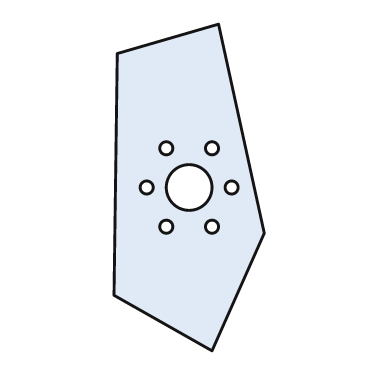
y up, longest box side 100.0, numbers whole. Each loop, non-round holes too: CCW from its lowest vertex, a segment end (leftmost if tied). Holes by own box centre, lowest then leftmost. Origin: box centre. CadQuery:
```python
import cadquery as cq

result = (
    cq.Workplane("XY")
    .moveTo(7.0, -50.0)
    .lineTo(23.0, -14.0)
    .lineTo(9.0, 50.0)
    .lineTo(-22.0, 41.0)
    .lineTo(-23.0, -33.0)
    .close()
    .moveTo(-7.0, -12.0)
    .circle(2.0)
    .moveTo(7.0, -12.0)
    .circle(2.0)
    .moveTo(-13.0, 0.0)
    .circle(2.0)
    .moveTo(0.0, 0.0)
    .circle(7.0)
    .moveTo(13.0, 0.0)
    .circle(2.0)
    .moveTo(-7.0, 12.0)
    .circle(2.0)
    .moveTo(7.0, 12.0)
    .circle(2.0)
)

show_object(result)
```